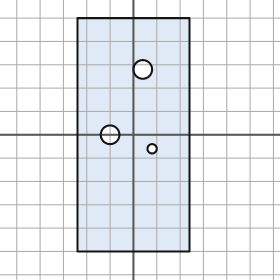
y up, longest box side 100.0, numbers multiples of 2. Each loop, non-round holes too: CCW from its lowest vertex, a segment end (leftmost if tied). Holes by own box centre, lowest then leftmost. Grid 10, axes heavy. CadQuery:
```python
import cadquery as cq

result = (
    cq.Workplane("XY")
    .moveTo(-24.0, -50.0)
    .lineTo(24.0, -50.0)
    .lineTo(24.0, 50.0)
    .lineTo(-24.0, 50.0)
    .close()
    .moveTo(8.0, -6.0)
    .circle(2.0)
    .moveTo(-10.0, 0.0)
    .circle(4.0)
    .moveTo(4.0, 28.0)
    .circle(4.0)
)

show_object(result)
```